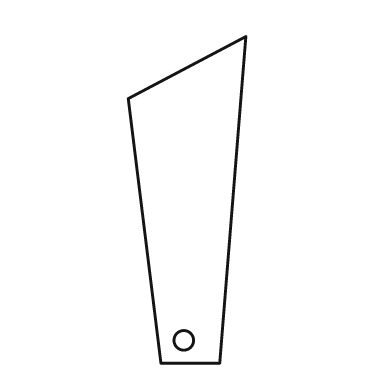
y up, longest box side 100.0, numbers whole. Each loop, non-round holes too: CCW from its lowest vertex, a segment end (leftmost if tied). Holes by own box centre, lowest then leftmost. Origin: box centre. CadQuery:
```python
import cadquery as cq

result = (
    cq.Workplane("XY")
    .moveTo(-8.0, -50.0)
    .lineTo(10.0, -50.0)
    .lineTo(18.0, 50.0)
    .lineTo(-18.0, 31.0)
    .close()
    .moveTo(-1.0, -43.0)
    .circle(3.0)
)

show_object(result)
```